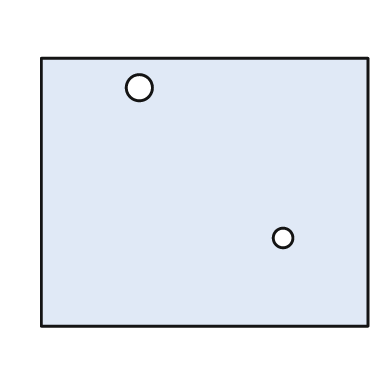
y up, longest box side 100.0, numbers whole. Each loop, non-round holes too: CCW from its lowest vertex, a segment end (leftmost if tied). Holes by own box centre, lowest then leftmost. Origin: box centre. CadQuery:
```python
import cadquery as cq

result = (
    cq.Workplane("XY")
    .moveTo(-50.0, -41.0)
    .lineTo(50.0, -41.0)
    .lineTo(50.0, 41.0)
    .lineTo(-50.0, 41.0)
    .close()
    .moveTo(24.0, -14.0)
    .circle(3.0)
    .moveTo(-20.0, 32.0)
    .circle(4.0)
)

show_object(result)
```